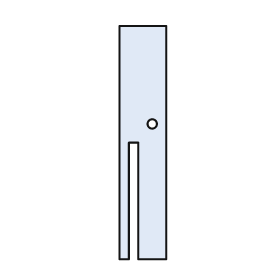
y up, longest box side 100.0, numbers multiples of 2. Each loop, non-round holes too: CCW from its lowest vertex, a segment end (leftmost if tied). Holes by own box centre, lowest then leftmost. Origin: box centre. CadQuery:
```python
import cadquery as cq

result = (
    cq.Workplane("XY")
    .moveTo(-10.0, -50.0)
    .lineTo(-6.0, -50.0)
    .lineTo(-6.0, 0.0)
    .lineTo(-2.0, 0.0)
    .lineTo(-2.0, -50.0)
    .lineTo(10.0, -50.0)
    .lineTo(10.0, 50.0)
    .lineTo(-10.0, 50.0)
    .close()
    .moveTo(4.0, 8.0)
    .circle(2.0)
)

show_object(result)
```